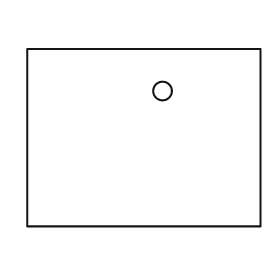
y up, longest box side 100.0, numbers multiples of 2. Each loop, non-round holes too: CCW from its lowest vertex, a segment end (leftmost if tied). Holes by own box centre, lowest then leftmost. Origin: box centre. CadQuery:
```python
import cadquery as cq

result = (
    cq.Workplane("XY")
    .moveTo(-50.0, -38.0)
    .lineTo(50.0, -38.0)
    .lineTo(50.0, 38.0)
    .lineTo(-50.0, 38.0)
    .close()
    .moveTo(8.0, 20.0)
    .circle(4.0)
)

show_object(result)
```